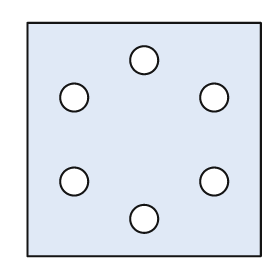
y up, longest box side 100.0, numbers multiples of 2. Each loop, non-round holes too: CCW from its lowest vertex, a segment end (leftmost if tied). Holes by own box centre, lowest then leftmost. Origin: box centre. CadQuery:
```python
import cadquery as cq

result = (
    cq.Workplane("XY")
    .moveTo(-50.0, -50.0)
    .lineTo(50.0, -50.0)
    .lineTo(50.0, 50.0)
    .lineTo(-50.0, 50.0)
    .close()
    .moveTo(0.0, -34.0)
    .circle(6.0)
    .moveTo(-30.0, -18.0)
    .circle(6.0)
    .moveTo(30.0, -18.0)
    .circle(6.0)
    .moveTo(-30.0, 18.0)
    .circle(6.0)
    .moveTo(30.0, 18.0)
    .circle(6.0)
    .moveTo(0.0, 34.0)
    .circle(6.0)
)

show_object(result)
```